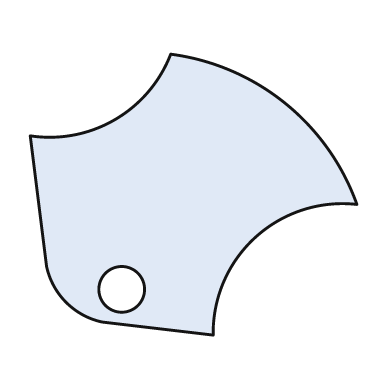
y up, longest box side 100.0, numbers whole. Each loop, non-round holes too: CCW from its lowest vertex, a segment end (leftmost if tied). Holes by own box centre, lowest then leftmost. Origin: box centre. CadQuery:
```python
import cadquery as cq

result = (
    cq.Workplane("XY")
    .moveTo(6.0, -43.0)
    .threePointArc((19.0, -13.0), (50.0, -3.0))
    .threePointArc((28.0, 28.0), (-7.0, 43.0))
    .threePointArc((-24.0, 23.0), (-50.0, 18.0))
    .lineTo(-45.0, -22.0)
    .threePointArc((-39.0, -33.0), (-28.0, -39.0))
    .close()
    .moveTo(-22.0, -29.0)
    .circle(7.0)
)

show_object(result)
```